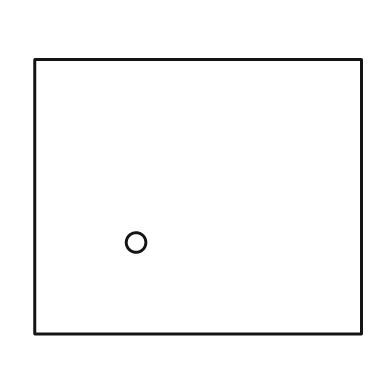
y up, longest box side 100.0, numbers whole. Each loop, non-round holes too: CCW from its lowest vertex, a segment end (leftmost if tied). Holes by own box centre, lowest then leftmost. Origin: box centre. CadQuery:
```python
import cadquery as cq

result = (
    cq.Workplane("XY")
    .moveTo(-50.0, -42.0)
    .lineTo(50.0, -42.0)
    .lineTo(50.0, 42.0)
    .lineTo(-50.0, 42.0)
    .close()
    .moveTo(-19.0, -14.0)
    .circle(3.0)
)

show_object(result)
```